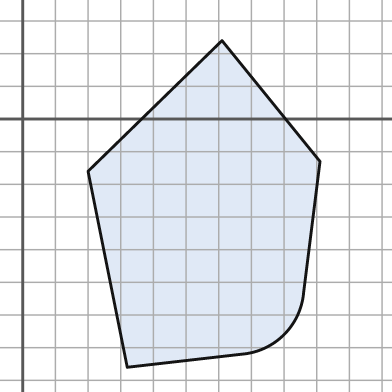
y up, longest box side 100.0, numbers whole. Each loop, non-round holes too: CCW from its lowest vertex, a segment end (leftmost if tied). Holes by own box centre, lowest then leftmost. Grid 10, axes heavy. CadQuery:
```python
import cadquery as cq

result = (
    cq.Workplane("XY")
    .moveTo(32.0, -76.0)
    .lineTo(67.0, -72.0)
    .threePointArc((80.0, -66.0), (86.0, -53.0))
    .lineTo(91.0, -13.0)
    .lineTo(61.0, 24.0)
    .lineTo(20.0, -16.0)
    .close()
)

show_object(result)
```